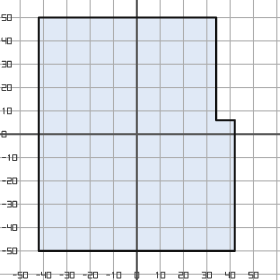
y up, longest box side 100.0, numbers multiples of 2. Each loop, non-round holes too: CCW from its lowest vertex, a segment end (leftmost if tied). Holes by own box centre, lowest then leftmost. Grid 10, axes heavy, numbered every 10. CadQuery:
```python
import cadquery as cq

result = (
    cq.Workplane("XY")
    .moveTo(-42.0, -50.0)
    .lineTo(42.0, -50.0)
    .lineTo(42.0, 6.0)
    .lineTo(34.0, 6.0)
    .lineTo(34.0, 50.0)
    .lineTo(-42.0, 50.0)
    .close()
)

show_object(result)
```